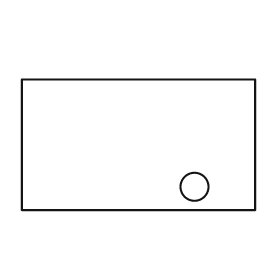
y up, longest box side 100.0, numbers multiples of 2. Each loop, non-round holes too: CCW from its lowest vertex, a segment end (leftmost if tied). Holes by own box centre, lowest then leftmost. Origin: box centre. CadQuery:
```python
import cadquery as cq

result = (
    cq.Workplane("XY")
    .moveTo(-50.0, -28.0)
    .lineTo(50.0, -28.0)
    .lineTo(50.0, 28.0)
    .lineTo(-50.0, 28.0)
    .close()
    .moveTo(24.0, -18.0)
    .circle(6.0)
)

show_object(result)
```